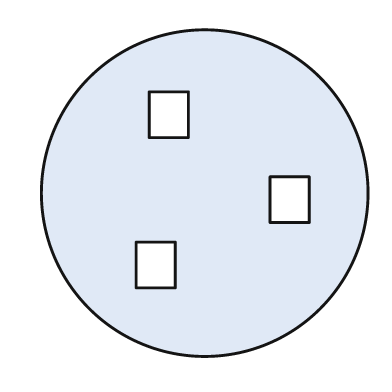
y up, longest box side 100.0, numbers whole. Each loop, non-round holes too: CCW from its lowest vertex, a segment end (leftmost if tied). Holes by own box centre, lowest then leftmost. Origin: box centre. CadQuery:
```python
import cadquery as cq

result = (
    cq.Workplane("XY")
    .moveTo(0.0, 0.0)
    .circle(50.0)
    .moveTo(-21.0, -29.0)
    .lineTo(-9.0, -29.0)
    .lineTo(-9.0, -15.0)
    .lineTo(-21.0, -15.0)
    .close()
    .moveTo(20.0, -9.0)
    .lineTo(32.0, -9.0)
    .lineTo(32.0, 5.0)
    .lineTo(20.0, 5.0)
    .close()
    .moveTo(-17.0, 17.0)
    .lineTo(-5.0, 17.0)
    .lineTo(-5.0, 31.0)
    .lineTo(-17.0, 31.0)
    .close()
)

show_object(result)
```